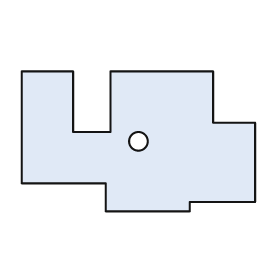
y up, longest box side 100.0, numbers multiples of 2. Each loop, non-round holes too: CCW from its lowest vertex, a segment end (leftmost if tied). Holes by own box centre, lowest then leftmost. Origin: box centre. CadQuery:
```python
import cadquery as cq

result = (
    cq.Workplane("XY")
    .moveTo(-14.0, -30.0)
    .lineTo(22.0, -30.0)
    .lineTo(22.0, -26.0)
    .lineTo(50.0, -26.0)
    .lineTo(50.0, 8.0)
    .lineTo(32.0, 8.0)
    .lineTo(32.0, 30.0)
    .lineTo(-12.0, 30.0)
    .lineTo(-12.0, 4.0)
    .lineTo(-28.0, 4.0)
    .lineTo(-28.0, 30.0)
    .lineTo(-50.0, 30.0)
    .lineTo(-50.0, -18.0)
    .lineTo(-14.0, -18.0)
    .close()
    .moveTo(0.0, 0.0)
    .circle(4.0)
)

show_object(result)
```